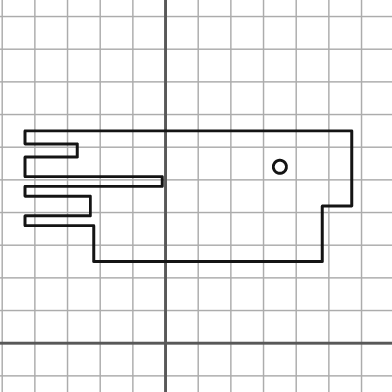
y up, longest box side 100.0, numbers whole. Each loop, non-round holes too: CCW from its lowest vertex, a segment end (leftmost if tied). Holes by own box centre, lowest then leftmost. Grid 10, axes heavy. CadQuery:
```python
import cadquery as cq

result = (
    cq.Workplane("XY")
    .moveTo(-22.0, 25.0)
    .lineTo(48.0, 25.0)
    .lineTo(48.0, 42.0)
    .lineTo(57.0, 42.0)
    .lineTo(57.0, 65.0)
    .lineTo(-43.0, 65.0)
    .lineTo(-43.0, 61.0)
    .lineTo(-27.0, 61.0)
    .lineTo(-27.0, 57.0)
    .lineTo(-43.0, 57.0)
    .lineTo(-43.0, 51.0)
    .lineTo(-1.0, 51.0)
    .lineTo(-1.0, 48.0)
    .lineTo(-43.0, 48.0)
    .lineTo(-43.0, 45.0)
    .lineTo(-23.0, 45.0)
    .lineTo(-23.0, 39.0)
    .lineTo(-43.0, 39.0)
    .lineTo(-43.0, 36.0)
    .lineTo(-22.0, 36.0)
    .close()
    .moveTo(35.0, 54.0)
    .circle(2.0)
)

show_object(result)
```